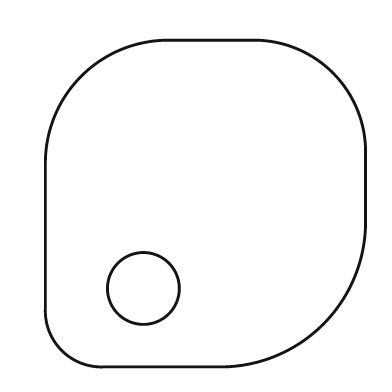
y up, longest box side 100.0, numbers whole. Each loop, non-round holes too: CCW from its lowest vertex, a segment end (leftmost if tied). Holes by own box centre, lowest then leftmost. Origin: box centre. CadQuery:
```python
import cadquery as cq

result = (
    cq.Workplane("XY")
    .moveTo(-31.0, -50.0)
    .lineTo(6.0, -50.0)
    .threePointArc((36.0, -37.0), (49.0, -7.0))
    .lineTo(49.0, 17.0)
    .threePointArc((39.0, 40.0), (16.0, 50.0))
    .lineTo(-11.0, 50.0)
    .threePointArc((-38.0, 39.0), (-49.0, 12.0))
    .lineTo(-49.0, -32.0)
    .threePointArc((-44.0, -45.0), (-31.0, -50.0))
    .close()
    .moveTo(-19.0, -26.0)
    .circle(11.0)
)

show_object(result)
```